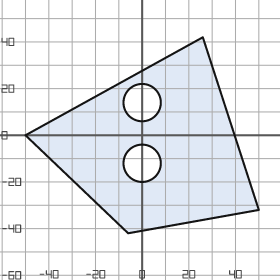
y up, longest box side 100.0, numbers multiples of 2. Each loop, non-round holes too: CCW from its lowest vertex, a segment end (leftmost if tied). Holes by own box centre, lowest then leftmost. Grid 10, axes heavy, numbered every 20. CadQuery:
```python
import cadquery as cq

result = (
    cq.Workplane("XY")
    .moveTo(-6.0, -42.0)
    .lineTo(50.0, -32.0)
    .lineTo(26.0, 42.0)
    .lineTo(-50.0, 0.0)
    .close()
    .moveTo(0.0, -12.0)
    .circle(8.0)
    .moveTo(0.0, 14.0)
    .circle(8.0)
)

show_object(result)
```